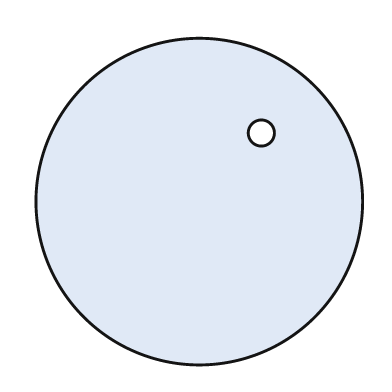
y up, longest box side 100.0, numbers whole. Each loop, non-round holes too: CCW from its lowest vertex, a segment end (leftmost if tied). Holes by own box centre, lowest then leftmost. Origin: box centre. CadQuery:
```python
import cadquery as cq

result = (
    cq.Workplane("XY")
    .moveTo(0.0, 0.0)
    .circle(50.0)
    .moveTo(19.0, 21.0)
    .circle(4.0)
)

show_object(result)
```